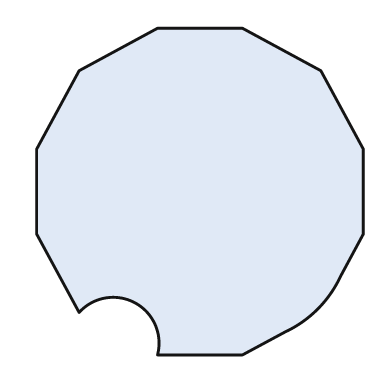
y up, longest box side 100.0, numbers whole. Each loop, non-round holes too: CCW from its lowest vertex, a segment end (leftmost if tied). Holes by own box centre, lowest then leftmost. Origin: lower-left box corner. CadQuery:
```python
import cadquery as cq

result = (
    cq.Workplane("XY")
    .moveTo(37.0, 0.0)
    .lineTo(63.0, 0.0)
    .lineTo(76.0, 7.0)
    .threePointArc((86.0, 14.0), (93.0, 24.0))
    .lineTo(100.0, 37.0)
    .lineTo(100.0, 63.0)
    .lineTo(87.0, 87.0)
    .lineTo(63.0, 100.0)
    .lineTo(37.0, 100.0)
    .lineTo(13.0, 87.0)
    .lineTo(0.0, 63.0)
    .lineTo(0.0, 37.0)
    .lineTo(13.0, 13.0)
    .threePointArc((30.0, 16.0), (37.0, 0.0))
    .close()
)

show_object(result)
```